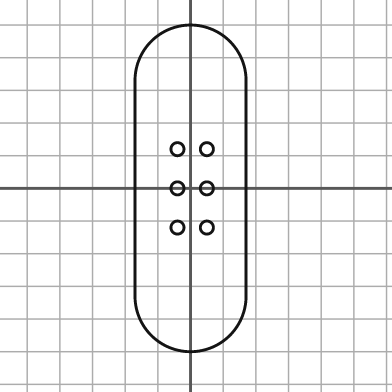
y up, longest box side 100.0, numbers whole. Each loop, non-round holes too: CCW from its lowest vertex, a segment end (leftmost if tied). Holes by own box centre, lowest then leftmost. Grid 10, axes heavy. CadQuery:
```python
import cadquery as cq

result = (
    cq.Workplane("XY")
    .moveTo(-17.0, -33.0)
    .threePointArc((0.0, -50.0), (17.0, -33.0))
    .lineTo(17.0, 33.0)
    .threePointArc((0.0, 50.0), (-17.0, 33.0))
    .close()
    .moveTo(-4.0, -12.0)
    .circle(2.0)
    .moveTo(5.0, -12.0)
    .circle(2.0)
    .moveTo(-4.0, 0.0)
    .circle(2.0)
    .moveTo(5.0, 0.0)
    .circle(2.0)
    .moveTo(-4.0, 12.0)
    .circle(2.0)
    .moveTo(5.0, 12.0)
    .circle(2.0)
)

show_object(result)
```